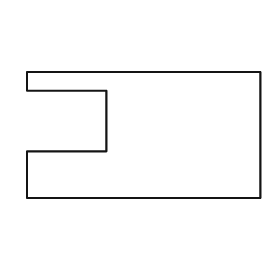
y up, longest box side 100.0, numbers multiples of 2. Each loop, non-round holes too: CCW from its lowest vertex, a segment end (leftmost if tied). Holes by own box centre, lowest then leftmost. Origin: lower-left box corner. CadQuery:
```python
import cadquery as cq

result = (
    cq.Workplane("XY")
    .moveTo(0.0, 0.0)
    .lineTo(100.0, 0.0)
    .lineTo(100.0, 54.0)
    .lineTo(0.0, 54.0)
    .lineTo(0.0, 46.0)
    .lineTo(34.0, 46.0)
    .lineTo(34.0, 20.0)
    .lineTo(0.0, 20.0)
    .close()
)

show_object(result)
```